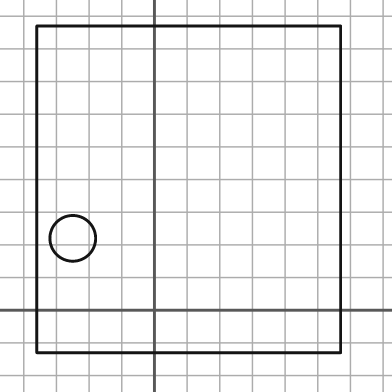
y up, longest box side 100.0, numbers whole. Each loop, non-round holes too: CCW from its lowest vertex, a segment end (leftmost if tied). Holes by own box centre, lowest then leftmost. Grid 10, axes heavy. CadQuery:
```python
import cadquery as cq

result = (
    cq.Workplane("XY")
    .moveTo(-36.0, -13.0)
    .lineTo(57.0, -13.0)
    .lineTo(57.0, 87.0)
    .lineTo(-36.0, 87.0)
    .close()
    .moveTo(-25.0, 22.0)
    .circle(7.0)
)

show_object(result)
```